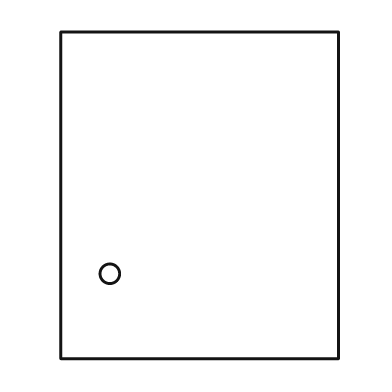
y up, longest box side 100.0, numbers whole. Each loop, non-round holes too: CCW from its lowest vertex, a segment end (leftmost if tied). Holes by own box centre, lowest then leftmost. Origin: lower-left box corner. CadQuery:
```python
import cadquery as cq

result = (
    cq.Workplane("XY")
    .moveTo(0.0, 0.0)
    .lineTo(85.0, 0.0)
    .lineTo(85.0, 100.0)
    .lineTo(0.0, 100.0)
    .close()
    .moveTo(15.0, 26.0)
    .circle(3.0)
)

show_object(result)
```